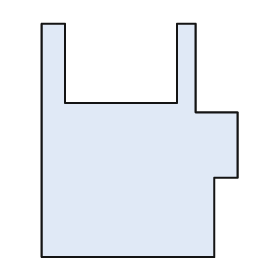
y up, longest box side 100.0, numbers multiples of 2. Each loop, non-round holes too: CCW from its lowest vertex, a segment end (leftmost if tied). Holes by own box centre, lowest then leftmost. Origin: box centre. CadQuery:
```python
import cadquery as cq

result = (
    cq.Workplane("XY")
    .moveTo(-42.0, -50.0)
    .lineTo(32.0, -50.0)
    .lineTo(32.0, -16.0)
    .lineTo(42.0, -16.0)
    .lineTo(42.0, 12.0)
    .lineTo(24.0, 12.0)
    .lineTo(24.0, 50.0)
    .lineTo(16.0, 50.0)
    .lineTo(16.0, 16.0)
    .lineTo(-32.0, 16.0)
    .lineTo(-32.0, 50.0)
    .lineTo(-42.0, 50.0)
    .close()
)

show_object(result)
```